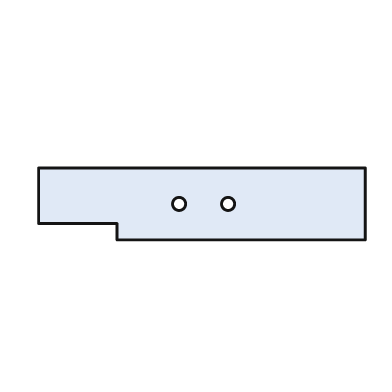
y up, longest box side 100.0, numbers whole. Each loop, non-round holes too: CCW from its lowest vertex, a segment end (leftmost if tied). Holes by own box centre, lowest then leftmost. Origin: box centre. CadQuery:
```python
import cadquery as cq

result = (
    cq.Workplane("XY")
    .moveTo(-26.0, -11.0)
    .lineTo(50.0, -11.0)
    .lineTo(50.0, 11.0)
    .lineTo(-50.0, 11.0)
    .lineTo(-50.0, -6.0)
    .lineTo(-26.0, -6.0)
    .close()
    .moveTo(-7.0, 0.0)
    .circle(2.0)
    .moveTo(8.0, 0.0)
    .circle(2.0)
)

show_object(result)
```